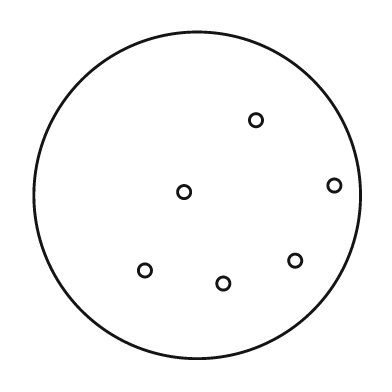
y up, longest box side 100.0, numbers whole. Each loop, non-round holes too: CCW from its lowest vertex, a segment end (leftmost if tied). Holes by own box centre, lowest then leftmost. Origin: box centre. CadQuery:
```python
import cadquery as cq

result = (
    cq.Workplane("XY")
    .moveTo(0.0, 0.0)
    .circle(50.0)
    .moveTo(8.0, -27.0)
    .circle(2.0)
    .moveTo(-16.0, -23.0)
    .circle(2.0)
    .moveTo(30.0, -20.0)
    .circle(2.0)
    .moveTo(-4.0, 1.0)
    .circle(2.0)
    .moveTo(42.0, 3.0)
    .circle(2.0)
    .moveTo(18.0, 23.0)
    .circle(2.0)
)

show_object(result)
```